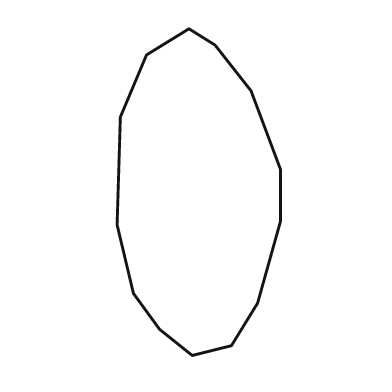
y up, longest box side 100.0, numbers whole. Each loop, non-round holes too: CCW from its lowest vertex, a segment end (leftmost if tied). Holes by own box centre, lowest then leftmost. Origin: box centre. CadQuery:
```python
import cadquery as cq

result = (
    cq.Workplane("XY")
    .moveTo(-2.0, -50.0)
    .lineTo(10.0, -47.0)
    .lineTo(18.0, -34.0)
    .lineTo(25.0, -9.0)
    .lineTo(25.0, 7.0)
    .lineTo(16.0, 31.0)
    .lineTo(5.0, 45.0)
    .lineTo(-3.0, 50.0)
    .lineTo(-16.0, 42.0)
    .lineTo(-24.0, 23.0)
    .lineTo(-25.0, -10.0)
    .lineTo(-20.0, -31.0)
    .lineTo(-12.0, -42.0)
    .close()
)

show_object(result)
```